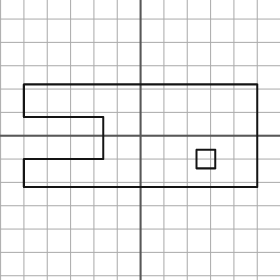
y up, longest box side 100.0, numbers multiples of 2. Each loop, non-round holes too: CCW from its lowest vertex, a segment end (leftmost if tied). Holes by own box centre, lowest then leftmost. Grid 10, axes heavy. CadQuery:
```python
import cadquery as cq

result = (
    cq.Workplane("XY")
    .moveTo(-50.0, -22.0)
    .lineTo(50.0, -22.0)
    .lineTo(50.0, 22.0)
    .lineTo(-50.0, 22.0)
    .lineTo(-50.0, 8.0)
    .lineTo(-16.0, 8.0)
    .lineTo(-16.0, -10.0)
    .lineTo(-50.0, -10.0)
    .close()
    .moveTo(24.0, -14.0)
    .lineTo(32.0, -14.0)
    .lineTo(32.0, -6.0)
    .lineTo(24.0, -6.0)
    .close()
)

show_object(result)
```